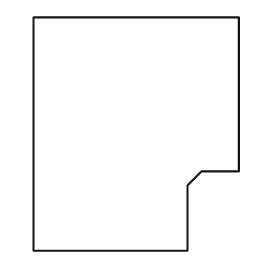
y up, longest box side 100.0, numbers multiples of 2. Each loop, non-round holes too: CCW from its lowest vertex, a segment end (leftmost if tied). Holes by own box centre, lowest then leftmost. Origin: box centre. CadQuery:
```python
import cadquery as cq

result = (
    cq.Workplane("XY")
    .moveTo(-44.0, -50.0)
    .lineTo(22.0, -50.0)
    .lineTo(22.0, -22.0)
    .lineTo(28.0, -16.0)
    .lineTo(44.0, -16.0)
    .lineTo(44.0, 50.0)
    .lineTo(-44.0, 50.0)
    .close()
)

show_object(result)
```